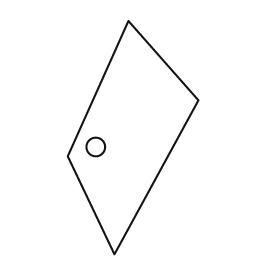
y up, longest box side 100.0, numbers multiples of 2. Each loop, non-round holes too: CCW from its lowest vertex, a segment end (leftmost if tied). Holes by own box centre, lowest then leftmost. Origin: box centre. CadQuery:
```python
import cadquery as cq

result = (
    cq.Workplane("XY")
    .moveTo(-8.0, -50.0)
    .lineTo(28.0, 16.0)
    .lineTo(-2.0, 50.0)
    .lineTo(-28.0, -8.0)
    .close()
    .moveTo(-16.0, -4.0)
    .circle(4.0)
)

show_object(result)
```